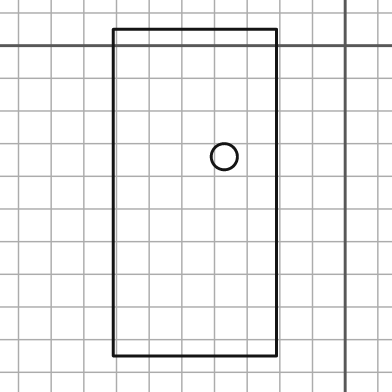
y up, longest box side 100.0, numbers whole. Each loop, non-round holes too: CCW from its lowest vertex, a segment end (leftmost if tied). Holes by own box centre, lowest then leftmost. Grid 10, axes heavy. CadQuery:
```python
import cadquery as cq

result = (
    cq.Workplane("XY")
    .moveTo(-71.0, -95.0)
    .lineTo(-21.0, -95.0)
    .lineTo(-21.0, 5.0)
    .lineTo(-71.0, 5.0)
    .close()
    .moveTo(-37.0, -34.0)
    .circle(4.0)
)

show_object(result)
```